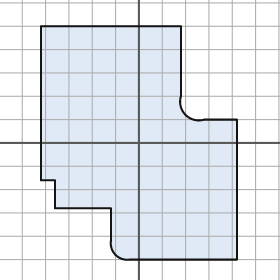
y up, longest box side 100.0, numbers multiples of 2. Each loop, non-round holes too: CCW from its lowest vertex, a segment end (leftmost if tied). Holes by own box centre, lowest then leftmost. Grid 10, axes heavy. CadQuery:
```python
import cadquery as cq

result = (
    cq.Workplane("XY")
    .moveTo(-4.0, -50.0)
    .lineTo(42.0, -50.0)
    .lineTo(42.0, 10.0)
    .lineTo(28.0, 10.0)
    .threePointArc((20.0, 12.0), (18.0, 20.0))
    .lineTo(18.0, 50.0)
    .lineTo(-42.0, 50.0)
    .lineTo(-42.0, -16.0)
    .lineTo(-36.0, -16.0)
    .lineTo(-36.0, -28.0)
    .lineTo(-12.0, -28.0)
    .lineTo(-12.0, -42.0)
    .threePointArc((-10.0, -48.0), (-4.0, -50.0))
    .close()
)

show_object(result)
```